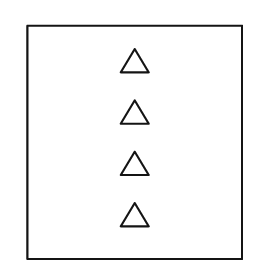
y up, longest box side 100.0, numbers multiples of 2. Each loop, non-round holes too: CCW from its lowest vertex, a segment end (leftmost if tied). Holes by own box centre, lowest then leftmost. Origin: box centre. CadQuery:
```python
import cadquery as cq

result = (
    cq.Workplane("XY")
    .moveTo(-46.0, -50.0)
    .lineTo(46.0, -50.0)
    .lineTo(46.0, 50.0)
    .lineTo(-46.0, 50.0)
    .close()
    .moveTo(-6.0, -36.0)
    .lineTo(6.0, -36.0)
    .lineTo(0.0, -26.0)
    .close()
    .moveTo(-6.0, -14.0)
    .lineTo(6.0, -14.0)
    .lineTo(0.0, -4.0)
    .close()
    .moveTo(-6.0, 8.0)
    .lineTo(6.0, 8.0)
    .lineTo(0.0, 18.0)
    .close()
    .moveTo(-6.0, 30.0)
    .lineTo(6.0, 30.0)
    .lineTo(0.0, 40.0)
    .close()
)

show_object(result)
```